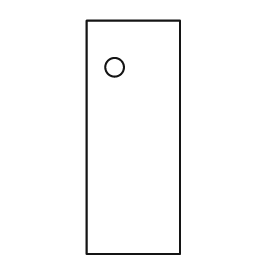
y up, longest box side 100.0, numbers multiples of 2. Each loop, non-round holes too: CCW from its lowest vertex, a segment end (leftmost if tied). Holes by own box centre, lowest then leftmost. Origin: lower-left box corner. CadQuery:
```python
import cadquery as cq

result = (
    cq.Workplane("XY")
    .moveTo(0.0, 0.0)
    .lineTo(40.0, 0.0)
    .lineTo(40.0, 100.0)
    .lineTo(0.0, 100.0)
    .close()
    .moveTo(12.0, 80.0)
    .circle(4.0)
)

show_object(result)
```